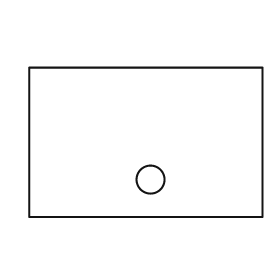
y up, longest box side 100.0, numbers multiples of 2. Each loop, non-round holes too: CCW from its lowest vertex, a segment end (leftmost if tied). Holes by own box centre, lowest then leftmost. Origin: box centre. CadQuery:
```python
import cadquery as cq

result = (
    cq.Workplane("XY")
    .moveTo(-50.0, -32.0)
    .lineTo(50.0, -32.0)
    .lineTo(50.0, 32.0)
    .lineTo(-50.0, 32.0)
    .close()
    .moveTo(2.0, -16.0)
    .circle(6.0)
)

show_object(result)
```